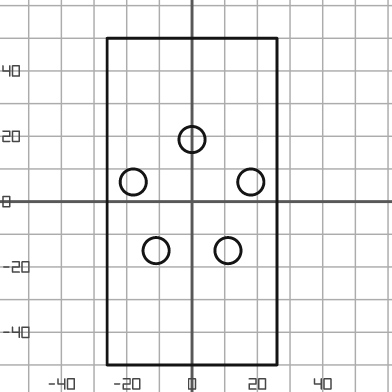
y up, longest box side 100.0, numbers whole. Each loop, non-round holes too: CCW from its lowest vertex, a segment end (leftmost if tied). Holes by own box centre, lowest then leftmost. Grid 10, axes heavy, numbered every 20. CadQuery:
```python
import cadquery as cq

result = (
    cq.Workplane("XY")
    .moveTo(-26.0, -50.0)
    .lineTo(26.0, -50.0)
    .lineTo(26.0, 50.0)
    .lineTo(-26.0, 50.0)
    .close()
    .moveTo(-11.0, -15.0)
    .circle(4.0)
    .moveTo(11.0, -15.0)
    .circle(4.0)
    .moveTo(-18.0, 6.0)
    .circle(4.0)
    .moveTo(18.0, 6.0)
    .circle(4.0)
    .moveTo(0.0, 19.0)
    .circle(4.0)
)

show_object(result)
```